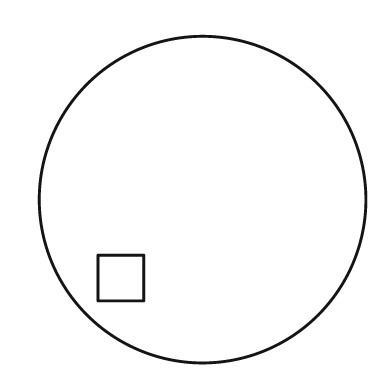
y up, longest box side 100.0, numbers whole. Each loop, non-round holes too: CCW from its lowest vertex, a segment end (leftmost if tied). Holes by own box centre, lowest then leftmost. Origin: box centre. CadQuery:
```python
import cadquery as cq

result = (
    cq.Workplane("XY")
    .moveTo(0.0, 0.0)
    .circle(50.0)
    .moveTo(-32.0, -31.0)
    .lineTo(-18.0, -31.0)
    .lineTo(-18.0, -17.0)
    .lineTo(-32.0, -17.0)
    .close()
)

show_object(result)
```